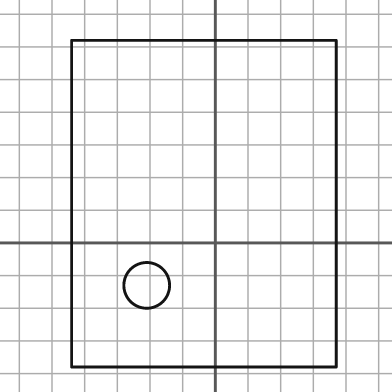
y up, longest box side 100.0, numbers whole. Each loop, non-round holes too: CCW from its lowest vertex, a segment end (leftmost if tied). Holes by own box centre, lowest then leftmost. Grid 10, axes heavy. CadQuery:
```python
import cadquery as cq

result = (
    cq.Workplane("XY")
    .moveTo(-44.0, -38.0)
    .lineTo(37.0, -38.0)
    .lineTo(37.0, 62.0)
    .lineTo(-44.0, 62.0)
    .close()
    .moveTo(-21.0, -13.0)
    .circle(7.0)
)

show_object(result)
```